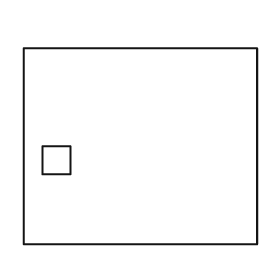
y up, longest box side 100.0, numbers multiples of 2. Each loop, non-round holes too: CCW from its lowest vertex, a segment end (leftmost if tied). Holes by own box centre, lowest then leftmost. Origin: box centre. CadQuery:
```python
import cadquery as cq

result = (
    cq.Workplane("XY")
    .moveTo(-50.0, -42.0)
    .lineTo(50.0, -42.0)
    .lineTo(50.0, 42.0)
    .lineTo(-50.0, 42.0)
    .close()
    .moveTo(-42.0, -12.0)
    .lineTo(-30.0, -12.0)
    .lineTo(-30.0, 0.0)
    .lineTo(-42.0, 0.0)
    .close()
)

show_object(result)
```